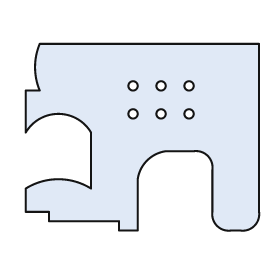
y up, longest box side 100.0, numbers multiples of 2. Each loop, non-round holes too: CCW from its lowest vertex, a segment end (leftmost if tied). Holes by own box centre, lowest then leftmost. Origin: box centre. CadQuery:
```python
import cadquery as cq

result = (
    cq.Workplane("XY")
    .moveTo(-10.0, -40.0)
    .lineTo(-2.0, -40.0)
    .lineTo(-2.0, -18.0)
    .threePointArc((2.0, -10.0), (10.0, -6.0))
    .lineTo(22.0, -6.0)
    .threePointArc((28.0, -8.0), (30.0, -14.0))
    .lineTo(30.0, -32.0)
    .threePointArc((32.0, -38.0), (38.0, -40.0))
    .lineTo(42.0, -40.0)
    .threePointArc((48.0, -38.0), (50.0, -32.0))
    .lineTo(50.0, 40.0)
    .lineTo(-44.0, 40.0)
    .threePointArc((-46.0, 30.0), (-44.0, 20.0))
    .lineTo(-50.0, 20.0)
    .lineTo(-50.0, 2.0)
    .threePointArc((-36.0, 10.0), (-22.0, 2.0))
    .lineTo(-22.0, -22.0)
    .threePointArc((-36.0, -18.0), (-50.0, -22.0))
    .lineTo(-50.0, -32.0)
    .lineTo(-40.0, -32.0)
    .lineTo(-40.0, -36.0)
    .lineTo(-10.0, -36.0)
    .close()
    .moveTo(-4.0, 10.0)
    .circle(2.0)
    .moveTo(8.0, 10.0)
    .circle(2.0)
    .moveTo(20.0, 10.0)
    .circle(2.0)
    .moveTo(-4.0, 22.0)
    .circle(2.0)
    .moveTo(8.0, 22.0)
    .circle(2.0)
    .moveTo(20.0, 22.0)
    .circle(2.0)
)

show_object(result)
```